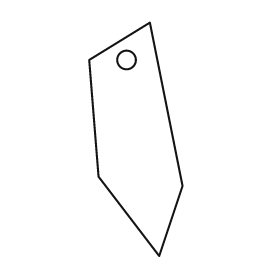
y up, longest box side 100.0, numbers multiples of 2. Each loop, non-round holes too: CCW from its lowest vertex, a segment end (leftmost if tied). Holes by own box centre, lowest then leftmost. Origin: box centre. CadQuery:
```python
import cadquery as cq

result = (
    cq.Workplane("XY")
    .moveTo(10.0, -50.0)
    .lineTo(20.0, -20.0)
    .lineTo(6.0, 50.0)
    .lineTo(-20.0, 34.0)
    .lineTo(-16.0, -16.0)
    .close()
    .moveTo(-4.0, 34.0)
    .circle(4.0)
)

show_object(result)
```